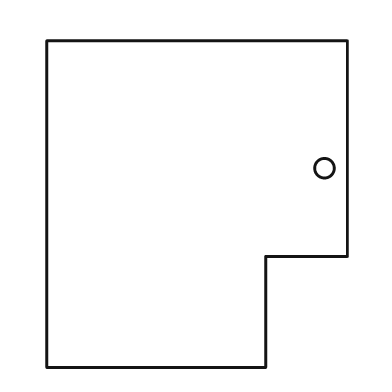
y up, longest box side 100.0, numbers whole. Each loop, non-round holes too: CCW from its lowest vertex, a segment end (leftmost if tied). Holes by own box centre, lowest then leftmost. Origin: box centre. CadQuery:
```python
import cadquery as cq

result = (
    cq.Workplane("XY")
    .moveTo(-46.0, -50.0)
    .lineTo(21.0, -50.0)
    .lineTo(21.0, -16.0)
    .lineTo(46.0, -16.0)
    .lineTo(46.0, 50.0)
    .lineTo(-46.0, 50.0)
    .close()
    .moveTo(39.0, 11.0)
    .circle(3.0)
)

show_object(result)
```